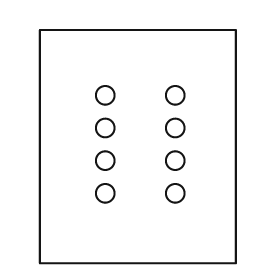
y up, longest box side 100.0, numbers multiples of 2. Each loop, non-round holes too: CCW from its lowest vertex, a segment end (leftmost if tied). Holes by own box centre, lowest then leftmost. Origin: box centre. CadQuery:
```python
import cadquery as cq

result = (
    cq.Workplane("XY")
    .moveTo(-42.0, -50.0)
    .lineTo(42.0, -50.0)
    .lineTo(42.0, 50.0)
    .lineTo(-42.0, 50.0)
    .close()
    .moveTo(-14.0, -20.0)
    .circle(4.0)
    .moveTo(16.0, -20.0)
    .circle(4.0)
    .moveTo(-14.0, -6.0)
    .circle(4.0)
    .moveTo(16.0, -6.0)
    .circle(4.0)
    .moveTo(-14.0, 8.0)
    .circle(4.0)
    .moveTo(16.0, 8.0)
    .circle(4.0)
    .moveTo(-14.0, 22.0)
    .circle(4.0)
    .moveTo(16.0, 22.0)
    .circle(4.0)
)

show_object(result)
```